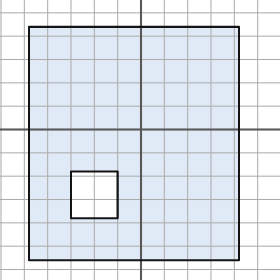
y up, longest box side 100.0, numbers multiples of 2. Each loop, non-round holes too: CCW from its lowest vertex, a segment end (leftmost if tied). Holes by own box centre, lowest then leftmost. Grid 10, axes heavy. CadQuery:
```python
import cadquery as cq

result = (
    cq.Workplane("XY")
    .moveTo(-48.0, -56.0)
    .lineTo(42.0, -56.0)
    .lineTo(42.0, 44.0)
    .lineTo(-48.0, 44.0)
    .close()
    .moveTo(-30.0, -38.0)
    .lineTo(-10.0, -38.0)
    .lineTo(-10.0, -18.0)
    .lineTo(-30.0, -18.0)
    .close()
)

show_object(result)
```